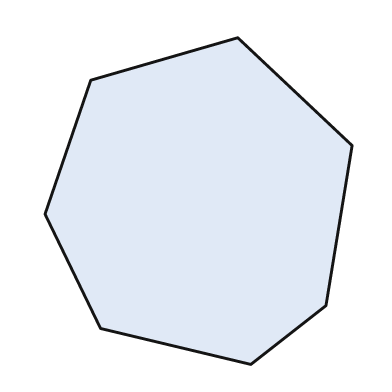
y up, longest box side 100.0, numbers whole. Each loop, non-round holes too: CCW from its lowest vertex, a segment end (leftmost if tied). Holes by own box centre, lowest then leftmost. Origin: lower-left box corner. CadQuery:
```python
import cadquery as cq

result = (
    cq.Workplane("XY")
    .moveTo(63.0, 0.0)
    .lineTo(86.0, 18.0)
    .lineTo(94.0, 67.0)
    .lineTo(59.0, 100.0)
    .lineTo(14.0, 87.0)
    .lineTo(0.0, 46.0)
    .lineTo(17.0, 11.0)
    .close()
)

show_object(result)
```